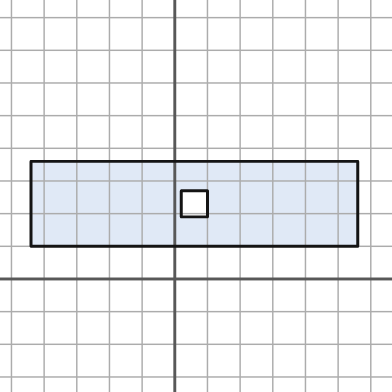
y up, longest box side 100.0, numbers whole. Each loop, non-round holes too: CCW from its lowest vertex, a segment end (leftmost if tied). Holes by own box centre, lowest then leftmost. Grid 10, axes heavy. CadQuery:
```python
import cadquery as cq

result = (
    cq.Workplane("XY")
    .moveTo(-44.0, 10.0)
    .lineTo(56.0, 10.0)
    .lineTo(56.0, 36.0)
    .lineTo(-44.0, 36.0)
    .close()
    .moveTo(2.0, 19.0)
    .lineTo(10.0, 19.0)
    .lineTo(10.0, 27.0)
    .lineTo(2.0, 27.0)
    .close()
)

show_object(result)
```